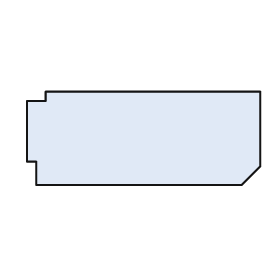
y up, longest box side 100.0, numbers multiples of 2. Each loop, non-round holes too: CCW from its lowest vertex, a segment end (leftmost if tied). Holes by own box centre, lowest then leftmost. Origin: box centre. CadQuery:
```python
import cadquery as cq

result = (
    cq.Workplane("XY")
    .moveTo(-46.0, -20.0)
    .lineTo(42.0, -20.0)
    .lineTo(50.0, -12.0)
    .lineTo(50.0, 20.0)
    .lineTo(-42.0, 20.0)
    .lineTo(-42.0, 16.0)
    .lineTo(-50.0, 16.0)
    .lineTo(-50.0, -10.0)
    .lineTo(-46.0, -10.0)
    .close()
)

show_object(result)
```